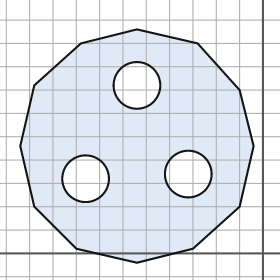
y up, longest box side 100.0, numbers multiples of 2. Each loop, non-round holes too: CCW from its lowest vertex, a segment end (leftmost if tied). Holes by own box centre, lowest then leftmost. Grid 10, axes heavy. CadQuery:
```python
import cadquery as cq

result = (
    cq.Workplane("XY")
    .moveTo(-54.0, -4.0)
    .lineTo(-30.0, 2.0)
    .lineTo(-10.0, 20.0)
    .lineTo(-4.0, 46.0)
    .lineTo(-10.0, 70.0)
    .lineTo(-28.0, 90.0)
    .lineTo(-54.0, 96.0)
    .lineTo(-78.0, 90.0)
    .lineTo(-98.0, 72.0)
    .lineTo(-104.0, 46.0)
    .lineTo(-98.0, 20.0)
    .lineTo(-80.0, 2.0)
    .close()
    .moveTo(-76.0, 32.0)
    .circle(10.0)
    .moveTo(-32.0, 34.0)
    .circle(10.0)
    .moveTo(-54.0, 72.0)
    .circle(10.0)
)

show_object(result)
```